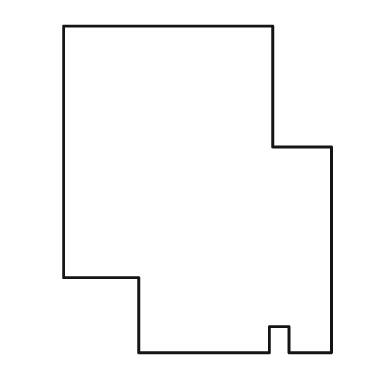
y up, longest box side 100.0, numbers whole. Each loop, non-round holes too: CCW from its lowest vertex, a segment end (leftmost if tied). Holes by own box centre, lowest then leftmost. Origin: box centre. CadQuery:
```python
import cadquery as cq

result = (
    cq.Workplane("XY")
    .moveTo(-18.0, -50.0)
    .lineTo(22.0, -50.0)
    .lineTo(22.0, -42.0)
    .lineTo(28.0, -42.0)
    .lineTo(28.0, -50.0)
    .lineTo(41.0, -50.0)
    .lineTo(41.0, 13.0)
    .lineTo(23.0, 13.0)
    .lineTo(23.0, 50.0)
    .lineTo(-41.0, 50.0)
    .lineTo(-41.0, -27.0)
    .lineTo(-18.0, -27.0)
    .close()
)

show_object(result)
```